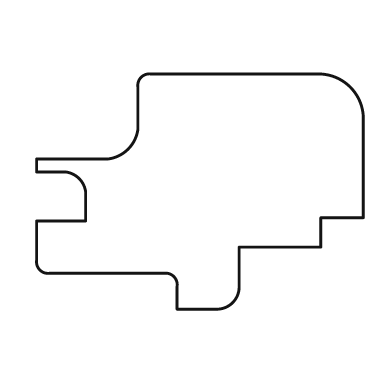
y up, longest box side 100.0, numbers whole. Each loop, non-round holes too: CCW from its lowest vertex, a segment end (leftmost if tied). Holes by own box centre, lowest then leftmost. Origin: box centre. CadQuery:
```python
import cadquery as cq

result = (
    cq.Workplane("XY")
    .moveTo(-7.0, -36.0)
    .lineTo(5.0, -36.0)
    .threePointArc((10.0, -34.0), (12.0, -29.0))
    .lineTo(12.0, -17.0)
    .lineTo(37.0, -17.0)
    .lineTo(37.0, -8.0)
    .lineTo(50.0, -8.0)
    .lineTo(50.0, 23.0)
    .threePointArc((46.0, 32.0), (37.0, 36.0))
    .lineTo(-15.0, 36.0)
    .threePointArc((-18.0, 35.0), (-19.0, 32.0))
    .lineTo(-19.0, 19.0)
    .threePointArc((-22.0, 13.0), (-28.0, 10.0))
    .lineTo(-50.0, 10.0)
    .lineTo(-50.0, 6.0)
    .lineTo(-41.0, 6.0)
    .threePointArc((-37.0, 4.0), (-35.0, 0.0))
    .lineTo(-35.0, -9.0)
    .lineTo(-50.0, -9.0)
    .lineTo(-50.0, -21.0)
    .threePointArc((-49.0, -24.0), (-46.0, -25.0))
    .lineTo(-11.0, -25.0)
    .threePointArc((-8.0, -26.0), (-7.0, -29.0))
    .close()
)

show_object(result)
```